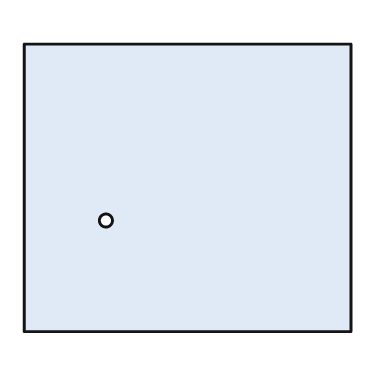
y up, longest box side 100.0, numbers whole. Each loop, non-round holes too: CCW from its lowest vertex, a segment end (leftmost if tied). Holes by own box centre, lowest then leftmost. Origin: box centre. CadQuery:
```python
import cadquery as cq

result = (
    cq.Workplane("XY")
    .moveTo(-50.0, -44.0)
    .lineTo(50.0, -44.0)
    .lineTo(50.0, 44.0)
    .lineTo(-50.0, 44.0)
    .close()
    .moveTo(-25.0, -10.0)
    .circle(2.0)
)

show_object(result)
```